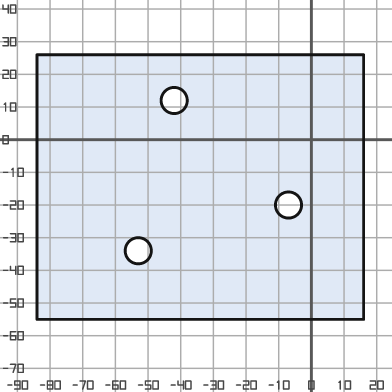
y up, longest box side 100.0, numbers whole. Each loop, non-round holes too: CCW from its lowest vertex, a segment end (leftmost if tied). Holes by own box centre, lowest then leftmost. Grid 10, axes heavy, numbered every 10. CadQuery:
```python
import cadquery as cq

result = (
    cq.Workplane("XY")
    .moveTo(-84.0, -55.0)
    .lineTo(16.0, -55.0)
    .lineTo(16.0, 26.0)
    .lineTo(-84.0, 26.0)
    .close()
    .moveTo(-53.0, -34.0)
    .circle(4.0)
    .moveTo(-7.0, -20.0)
    .circle(4.0)
    .moveTo(-42.0, 12.0)
    .circle(4.0)
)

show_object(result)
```